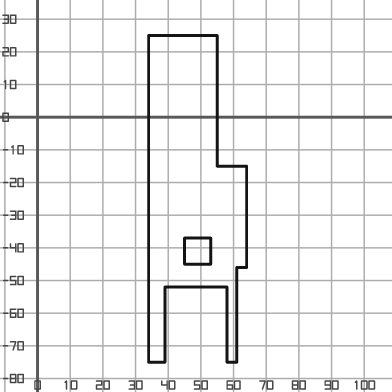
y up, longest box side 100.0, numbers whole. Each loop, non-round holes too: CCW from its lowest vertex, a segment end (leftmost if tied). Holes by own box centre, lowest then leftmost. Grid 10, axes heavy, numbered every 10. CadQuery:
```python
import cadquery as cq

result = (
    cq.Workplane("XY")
    .moveTo(34.0, -75.0)
    .lineTo(39.0, -75.0)
    .lineTo(39.0, -52.0)
    .lineTo(58.0, -52.0)
    .lineTo(58.0, -75.0)
    .lineTo(61.0, -75.0)
    .lineTo(61.0, -46.0)
    .lineTo(64.0, -46.0)
    .lineTo(64.0, -15.0)
    .lineTo(55.0, -15.0)
    .lineTo(55.0, 25.0)
    .lineTo(34.0, 25.0)
    .close()
    .moveTo(45.0, -45.0)
    .lineTo(53.0, -45.0)
    .lineTo(53.0, -37.0)
    .lineTo(45.0, -37.0)
    .close()
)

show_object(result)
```